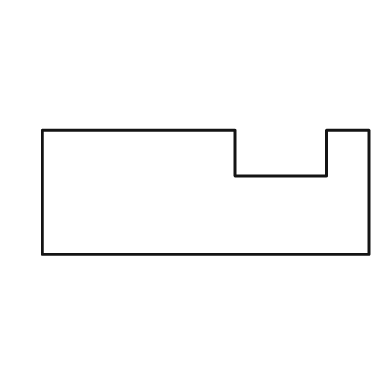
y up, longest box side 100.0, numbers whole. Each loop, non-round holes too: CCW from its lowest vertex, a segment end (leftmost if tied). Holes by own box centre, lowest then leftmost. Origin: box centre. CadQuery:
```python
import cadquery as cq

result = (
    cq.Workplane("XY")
    .moveTo(-50.0, -19.0)
    .lineTo(50.0, -19.0)
    .lineTo(50.0, 19.0)
    .lineTo(37.0, 19.0)
    .lineTo(37.0, 5.0)
    .lineTo(9.0, 5.0)
    .lineTo(9.0, 19.0)
    .lineTo(-50.0, 19.0)
    .close()
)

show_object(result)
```